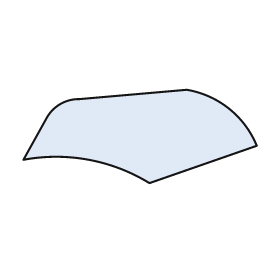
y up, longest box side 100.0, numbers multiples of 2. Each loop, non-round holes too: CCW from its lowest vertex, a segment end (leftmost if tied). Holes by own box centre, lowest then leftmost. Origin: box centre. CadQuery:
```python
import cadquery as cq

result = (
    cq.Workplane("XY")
    .moveTo(4.0, -20.0)
    .lineTo(50.0, -4.0)
    .threePointArc((38.0, 12.0), (20.0, 20.0))
    .lineTo(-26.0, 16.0)
    .threePointArc((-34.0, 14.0), (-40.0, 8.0))
    .lineTo(-50.0, -10.0)
    .threePointArc((-22.0, -10.0), (4.0, -20.0))
    .close()
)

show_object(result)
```